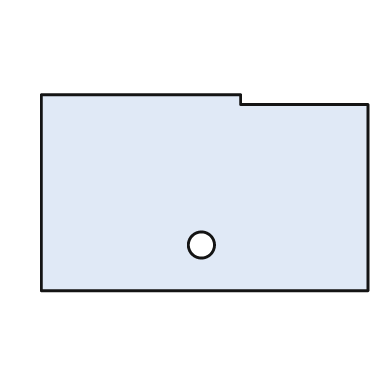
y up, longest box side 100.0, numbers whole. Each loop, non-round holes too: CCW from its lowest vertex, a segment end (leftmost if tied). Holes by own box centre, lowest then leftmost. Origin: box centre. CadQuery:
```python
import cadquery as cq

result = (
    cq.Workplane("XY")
    .moveTo(-50.0, -30.0)
    .lineTo(50.0, -30.0)
    .lineTo(50.0, 27.0)
    .lineTo(11.0, 27.0)
    .lineTo(11.0, 30.0)
    .lineTo(-50.0, 30.0)
    .close()
    .moveTo(-1.0, -16.0)
    .circle(4.0)
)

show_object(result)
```